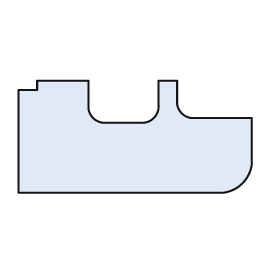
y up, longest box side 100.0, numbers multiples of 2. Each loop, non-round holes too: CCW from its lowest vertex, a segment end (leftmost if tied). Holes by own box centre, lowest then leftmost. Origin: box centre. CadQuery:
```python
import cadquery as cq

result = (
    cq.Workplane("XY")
    .moveTo(-50.0, -24.0)
    .lineTo(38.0, -24.0)
    .threePointArc((46.0, -20.0), (50.0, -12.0))
    .lineTo(50.0, 8.0)
    .lineTo(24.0, 8.0)
    .threePointArc((20.0, 10.0), (18.0, 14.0))
    .lineTo(18.0, 24.0)
    .lineTo(10.0, 24.0)
    .lineTo(10.0, 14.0)
    .threePointArc((8.0, 8.0), (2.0, 6.0))
    .lineTo(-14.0, 6.0)
    .threePointArc((-18.0, 8.0), (-20.0, 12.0))
    .lineTo(-20.0, 24.0)
    .lineTo(-42.0, 24.0)
    .lineTo(-42.0, 20.0)
    .lineTo(-50.0, 20.0)
    .close()
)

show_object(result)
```